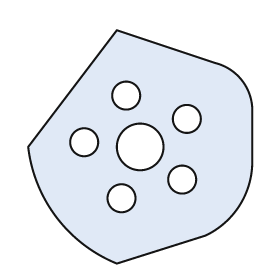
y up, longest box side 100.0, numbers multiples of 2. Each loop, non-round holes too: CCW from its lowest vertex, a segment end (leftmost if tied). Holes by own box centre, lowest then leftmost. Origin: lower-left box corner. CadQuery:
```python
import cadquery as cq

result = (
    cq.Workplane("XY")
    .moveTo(38.0, 0.0)
    .lineTo(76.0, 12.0)
    .threePointArc((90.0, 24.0), (96.0, 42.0))
    .lineTo(96.0, 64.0)
    .threePointArc((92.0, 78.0), (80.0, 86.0))
    .lineTo(38.0, 100.0)
    .lineTo(0.0, 50.0)
    .threePointArc((12.0, 20.0), (38.0, 0.0))
    .close()
    .moveTo(40.0, 28.0)
    .circle(6.0)
    .moveTo(66.0, 36.0)
    .circle(6.0)
    .moveTo(48.0, 50.0)
    .circle(10.0)
    .moveTo(24.0, 52.0)
    .circle(6.0)
    .moveTo(68.0, 62.0)
    .circle(6.0)
    .moveTo(42.0, 72.0)
    .circle(6.0)
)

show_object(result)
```